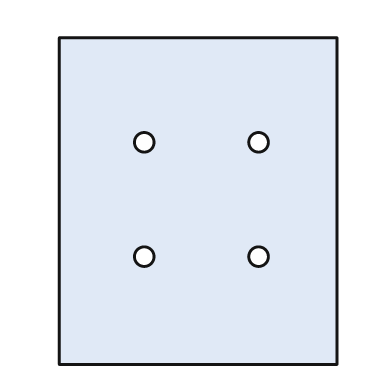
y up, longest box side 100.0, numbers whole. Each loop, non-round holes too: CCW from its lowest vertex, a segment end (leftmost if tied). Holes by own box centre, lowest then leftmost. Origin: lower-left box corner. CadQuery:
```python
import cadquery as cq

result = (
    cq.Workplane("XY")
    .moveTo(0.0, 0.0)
    .lineTo(85.0, 0.0)
    .lineTo(85.0, 100.0)
    .lineTo(0.0, 100.0)
    .close()
    .moveTo(26.0, 33.0)
    .circle(3.0)
    .moveTo(61.0, 33.0)
    .circle(3.0)
    .moveTo(26.0, 68.0)
    .circle(3.0)
    .moveTo(61.0, 68.0)
    .circle(3.0)
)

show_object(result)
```